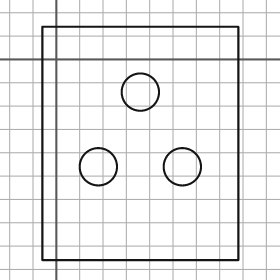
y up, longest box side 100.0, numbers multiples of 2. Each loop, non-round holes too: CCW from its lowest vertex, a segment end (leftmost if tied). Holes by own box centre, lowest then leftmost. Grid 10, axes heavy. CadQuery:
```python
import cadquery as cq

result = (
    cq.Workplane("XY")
    .moveTo(-6.0, -86.0)
    .lineTo(78.0, -86.0)
    .lineTo(78.0, 14.0)
    .lineTo(-6.0, 14.0)
    .close()
    .moveTo(18.0, -46.0)
    .circle(8.0)
    .moveTo(54.0, -46.0)
    .circle(8.0)
    .moveTo(36.0, -14.0)
    .circle(8.0)
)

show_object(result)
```